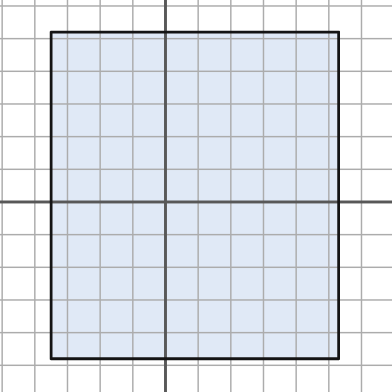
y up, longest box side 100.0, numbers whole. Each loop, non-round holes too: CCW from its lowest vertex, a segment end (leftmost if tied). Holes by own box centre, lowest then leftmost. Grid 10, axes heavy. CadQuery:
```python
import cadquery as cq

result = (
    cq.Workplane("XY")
    .moveTo(-35.0, -48.0)
    .lineTo(53.0, -48.0)
    .lineTo(53.0, 52.0)
    .lineTo(-35.0, 52.0)
    .close()
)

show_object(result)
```